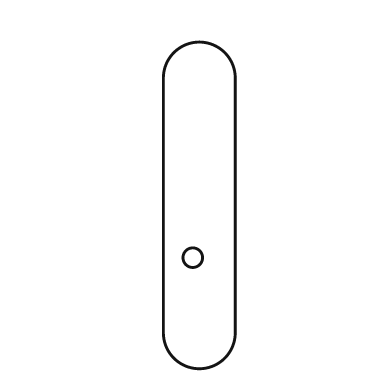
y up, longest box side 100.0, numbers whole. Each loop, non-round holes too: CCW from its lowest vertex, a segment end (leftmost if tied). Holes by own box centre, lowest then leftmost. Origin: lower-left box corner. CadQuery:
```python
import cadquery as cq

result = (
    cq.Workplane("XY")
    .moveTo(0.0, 11.0)
    .threePointArc((11.0, 0.0), (22.0, 11.0))
    .lineTo(22.0, 89.0)
    .threePointArc((11.0, 100.0), (0.0, 89.0))
    .close()
    .moveTo(9.0, 34.0)
    .circle(3.0)
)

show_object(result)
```